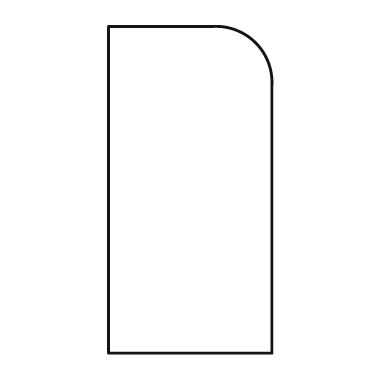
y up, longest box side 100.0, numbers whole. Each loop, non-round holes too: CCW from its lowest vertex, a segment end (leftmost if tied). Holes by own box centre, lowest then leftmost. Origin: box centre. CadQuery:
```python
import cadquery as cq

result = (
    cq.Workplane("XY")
    .moveTo(-25.0, -50.0)
    .lineTo(25.0, -50.0)
    .lineTo(25.0, 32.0)
    .threePointArc((20.0, 45.0), (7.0, 50.0))
    .lineTo(-25.0, 50.0)
    .close()
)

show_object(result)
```